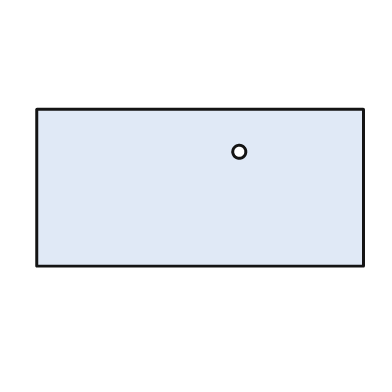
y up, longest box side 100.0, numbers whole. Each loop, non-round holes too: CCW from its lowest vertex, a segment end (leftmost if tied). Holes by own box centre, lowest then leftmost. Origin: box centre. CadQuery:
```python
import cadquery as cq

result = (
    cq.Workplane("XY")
    .moveTo(-50.0, -24.0)
    .lineTo(50.0, -24.0)
    .lineTo(50.0, 24.0)
    .lineTo(-50.0, 24.0)
    .close()
    .moveTo(12.0, 11.0)
    .circle(2.0)
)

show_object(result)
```